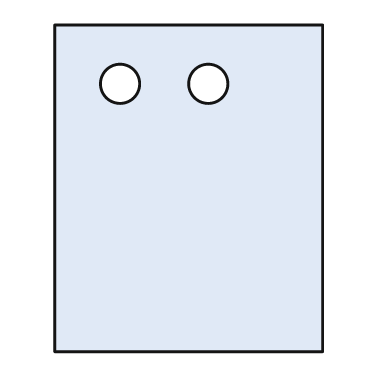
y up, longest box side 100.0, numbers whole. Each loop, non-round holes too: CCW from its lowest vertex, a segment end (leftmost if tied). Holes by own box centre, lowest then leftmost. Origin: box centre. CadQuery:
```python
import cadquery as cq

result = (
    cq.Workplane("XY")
    .moveTo(-41.0, -50.0)
    .lineTo(41.0, -50.0)
    .lineTo(41.0, 50.0)
    .lineTo(-41.0, 50.0)
    .close()
    .moveTo(-21.0, 32.0)
    .circle(6.0)
    .moveTo(6.0, 32.0)
    .circle(6.0)
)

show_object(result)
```